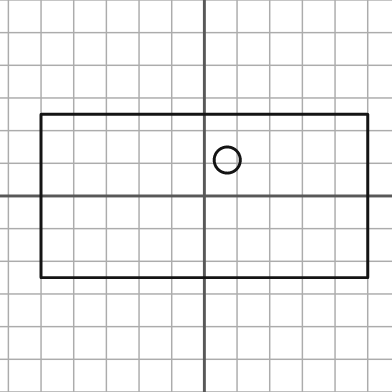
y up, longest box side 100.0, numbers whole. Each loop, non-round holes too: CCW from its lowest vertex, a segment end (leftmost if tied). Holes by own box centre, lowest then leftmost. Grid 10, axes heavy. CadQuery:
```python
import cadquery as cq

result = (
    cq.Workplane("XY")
    .moveTo(-50.0, -25.0)
    .lineTo(50.0, -25.0)
    .lineTo(50.0, 25.0)
    .lineTo(-50.0, 25.0)
    .close()
    .moveTo(7.0, 11.0)
    .circle(4.0)
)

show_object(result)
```